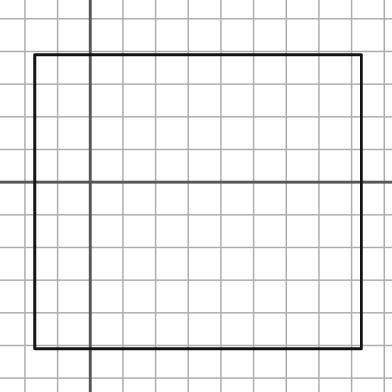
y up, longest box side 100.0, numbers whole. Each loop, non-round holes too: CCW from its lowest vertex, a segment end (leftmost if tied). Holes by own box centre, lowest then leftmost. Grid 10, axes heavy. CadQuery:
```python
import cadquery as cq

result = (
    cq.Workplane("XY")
    .moveTo(-17.0, -51.0)
    .lineTo(83.0, -51.0)
    .lineTo(83.0, 39.0)
    .lineTo(-17.0, 39.0)
    .close()
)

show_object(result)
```